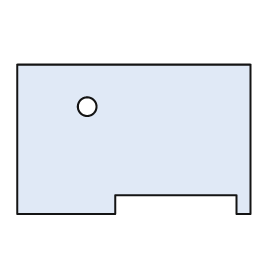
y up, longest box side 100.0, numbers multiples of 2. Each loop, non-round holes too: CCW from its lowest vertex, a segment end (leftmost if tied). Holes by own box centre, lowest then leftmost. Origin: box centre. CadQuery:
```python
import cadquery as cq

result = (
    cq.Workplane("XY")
    .moveTo(-50.0, -32.0)
    .lineTo(-8.0, -32.0)
    .lineTo(-8.0, -24.0)
    .lineTo(44.0, -24.0)
    .lineTo(44.0, -32.0)
    .lineTo(50.0, -32.0)
    .lineTo(50.0, 32.0)
    .lineTo(-50.0, 32.0)
    .close()
    .moveTo(-20.0, 14.0)
    .circle(4.0)
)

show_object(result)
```